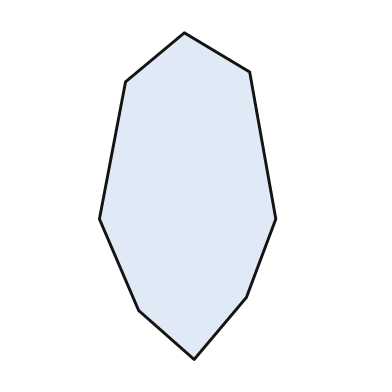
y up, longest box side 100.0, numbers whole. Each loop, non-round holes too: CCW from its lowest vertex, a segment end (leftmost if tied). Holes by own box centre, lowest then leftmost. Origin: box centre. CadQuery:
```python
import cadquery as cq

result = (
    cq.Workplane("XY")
    .moveTo(2.0, -50.0)
    .lineTo(18.0, -31.0)
    .lineTo(27.0, -7.0)
    .lineTo(19.0, 38.0)
    .lineTo(-1.0, 50.0)
    .lineTo(-19.0, 35.0)
    .lineTo(-27.0, -7.0)
    .lineTo(-15.0, -35.0)
    .close()
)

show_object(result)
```